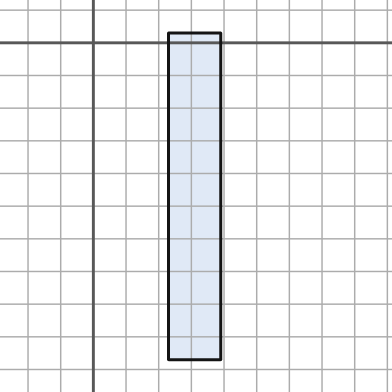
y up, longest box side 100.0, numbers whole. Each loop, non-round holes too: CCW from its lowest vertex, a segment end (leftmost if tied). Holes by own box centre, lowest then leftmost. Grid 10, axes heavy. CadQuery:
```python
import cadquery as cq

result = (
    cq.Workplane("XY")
    .moveTo(23.0, -97.0)
    .lineTo(39.0, -97.0)
    .lineTo(39.0, 3.0)
    .lineTo(23.0, 3.0)
    .close()
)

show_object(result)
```